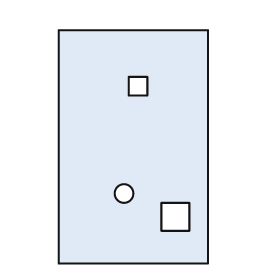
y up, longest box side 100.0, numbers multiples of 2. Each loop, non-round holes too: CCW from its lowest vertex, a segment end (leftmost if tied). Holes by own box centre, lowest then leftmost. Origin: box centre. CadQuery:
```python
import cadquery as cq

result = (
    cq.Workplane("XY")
    .moveTo(-32.0, -50.0)
    .lineTo(32.0, -50.0)
    .lineTo(32.0, 50.0)
    .lineTo(-32.0, 50.0)
    .close()
    .moveTo(12.0, -36.0)
    .lineTo(24.0, -36.0)
    .lineTo(24.0, -24.0)
    .lineTo(12.0, -24.0)
    .close()
    .moveTo(-4.0, -20.0)
    .circle(4.0)
    .moveTo(-2.0, 22.0)
    .lineTo(6.0, 22.0)
    .lineTo(6.0, 30.0)
    .lineTo(-2.0, 30.0)
    .close()
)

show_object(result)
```